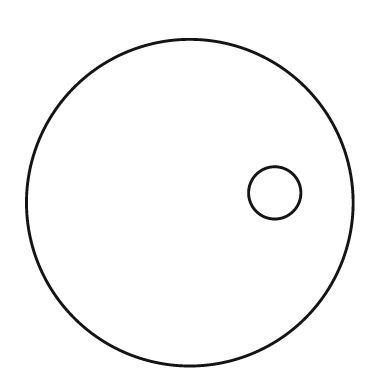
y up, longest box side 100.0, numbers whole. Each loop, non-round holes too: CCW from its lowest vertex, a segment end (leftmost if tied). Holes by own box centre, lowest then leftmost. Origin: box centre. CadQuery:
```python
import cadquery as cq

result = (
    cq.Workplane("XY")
    .moveTo(0.0, 0.0)
    .circle(50.0)
    .moveTo(26.0, 3.0)
    .circle(8.0)
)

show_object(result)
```